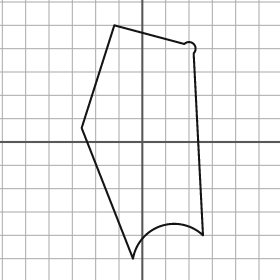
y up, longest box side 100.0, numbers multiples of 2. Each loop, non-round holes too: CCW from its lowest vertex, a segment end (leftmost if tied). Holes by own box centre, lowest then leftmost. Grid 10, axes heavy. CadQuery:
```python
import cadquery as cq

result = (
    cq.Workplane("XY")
    .moveTo(-4.0, -50.0)
    .threePointArc((8.0, -36.0), (26.0, -40.0))
    .lineTo(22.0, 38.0)
    .threePointArc((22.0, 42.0), (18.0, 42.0))
    .lineTo(-12.0, 50.0)
    .lineTo(-26.0, 6.0)
    .close()
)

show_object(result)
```